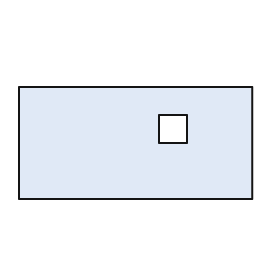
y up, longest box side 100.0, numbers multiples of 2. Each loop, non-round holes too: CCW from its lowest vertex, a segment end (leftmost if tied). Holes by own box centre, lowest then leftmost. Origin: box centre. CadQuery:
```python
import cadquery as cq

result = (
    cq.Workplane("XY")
    .moveTo(-50.0, -24.0)
    .lineTo(50.0, -24.0)
    .lineTo(50.0, 24.0)
    .lineTo(-50.0, 24.0)
    .close()
    .moveTo(10.0, 0.0)
    .lineTo(22.0, 0.0)
    .lineTo(22.0, 12.0)
    .lineTo(10.0, 12.0)
    .close()
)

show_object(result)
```